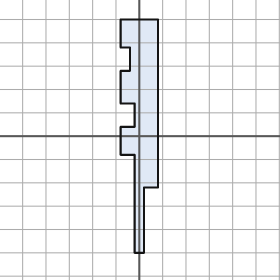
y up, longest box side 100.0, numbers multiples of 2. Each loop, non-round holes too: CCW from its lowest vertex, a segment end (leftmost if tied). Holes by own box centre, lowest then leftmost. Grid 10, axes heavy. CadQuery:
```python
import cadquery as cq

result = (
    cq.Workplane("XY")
    .moveTo(-2.0, -50.0)
    .lineTo(2.0, -50.0)
    .lineTo(2.0, -22.0)
    .lineTo(8.0, -22.0)
    .lineTo(8.0, 50.0)
    .lineTo(-8.0, 50.0)
    .lineTo(-8.0, 38.0)
    .lineTo(-4.0, 38.0)
    .lineTo(-4.0, 28.0)
    .lineTo(-8.0, 28.0)
    .lineTo(-8.0, 14.0)
    .lineTo(-2.0, 14.0)
    .lineTo(-2.0, 4.0)
    .lineTo(-8.0, 4.0)
    .lineTo(-8.0, -8.0)
    .lineTo(-2.0, -8.0)
    .close()
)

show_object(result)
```